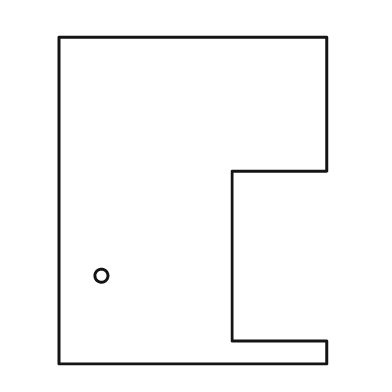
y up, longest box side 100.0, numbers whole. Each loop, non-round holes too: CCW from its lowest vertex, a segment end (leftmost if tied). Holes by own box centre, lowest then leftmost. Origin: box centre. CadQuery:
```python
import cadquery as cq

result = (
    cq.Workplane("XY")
    .moveTo(-41.0, -50.0)
    .lineTo(41.0, -50.0)
    .lineTo(41.0, -43.0)
    .lineTo(12.0, -43.0)
    .lineTo(12.0, 9.0)
    .lineTo(41.0, 9.0)
    .lineTo(41.0, 50.0)
    .lineTo(-41.0, 50.0)
    .close()
    .moveTo(-28.0, -23.0)
    .circle(2.0)
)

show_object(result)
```